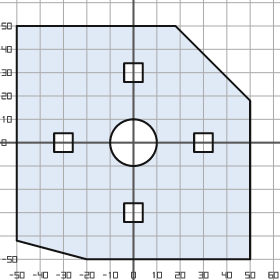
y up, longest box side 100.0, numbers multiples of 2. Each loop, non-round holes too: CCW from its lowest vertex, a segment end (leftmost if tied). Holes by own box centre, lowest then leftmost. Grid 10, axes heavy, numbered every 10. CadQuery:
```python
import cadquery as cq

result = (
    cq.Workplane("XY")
    .moveTo(-20.0, -50.0)
    .lineTo(50.0, -50.0)
    .lineTo(50.0, 18.0)
    .lineTo(18.0, 50.0)
    .lineTo(-50.0, 50.0)
    .lineTo(-50.0, -42.0)
    .close()
    .moveTo(-4.0, -34.0)
    .lineTo(4.0, -34.0)
    .lineTo(4.0, -26.0)
    .lineTo(-4.0, -26.0)
    .close()
    .moveTo(-34.0, -4.0)
    .lineTo(-26.0, -4.0)
    .lineTo(-26.0, 4.0)
    .lineTo(-34.0, 4.0)
    .close()
    .moveTo(0.0, 0.0)
    .circle(10.0)
    .moveTo(26.0, -4.0)
    .lineTo(34.0, -4.0)
    .lineTo(34.0, 4.0)
    .lineTo(26.0, 4.0)
    .close()
    .moveTo(-4.0, 26.0)
    .lineTo(4.0, 26.0)
    .lineTo(4.0, 34.0)
    .lineTo(-4.0, 34.0)
    .close()
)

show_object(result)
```